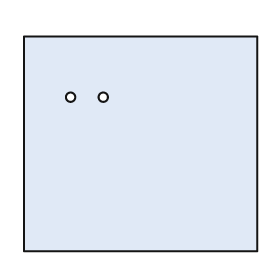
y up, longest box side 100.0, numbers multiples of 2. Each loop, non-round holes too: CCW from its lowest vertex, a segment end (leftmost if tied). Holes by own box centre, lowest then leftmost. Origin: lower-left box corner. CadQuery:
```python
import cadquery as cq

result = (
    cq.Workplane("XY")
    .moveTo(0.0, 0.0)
    .lineTo(100.0, 0.0)
    .lineTo(100.0, 92.0)
    .lineTo(0.0, 92.0)
    .close()
    .moveTo(20.0, 66.0)
    .circle(2.0)
    .moveTo(34.0, 66.0)
    .circle(2.0)
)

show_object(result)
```